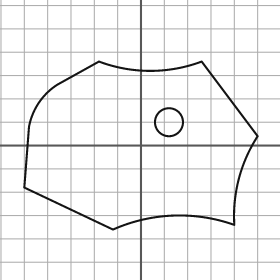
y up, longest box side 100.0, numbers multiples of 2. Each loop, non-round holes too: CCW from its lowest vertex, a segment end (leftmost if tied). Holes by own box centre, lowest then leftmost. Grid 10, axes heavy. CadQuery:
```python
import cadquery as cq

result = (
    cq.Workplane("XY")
    .moveTo(-12.0, -36.0)
    .threePointArc((14.0, -30.0), (40.0, -34.0))
    .threePointArc((42.0, -14.0), (50.0, 4.0))
    .lineTo(26.0, 36.0)
    .threePointArc((4.0, 32.0), (-18.0, 36.0))
    .lineTo(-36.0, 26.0)
    .threePointArc((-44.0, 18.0), (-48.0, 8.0))
    .lineTo(-50.0, -18.0)
    .close()
    .moveTo(12.0, 10.0)
    .circle(6.0)
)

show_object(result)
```